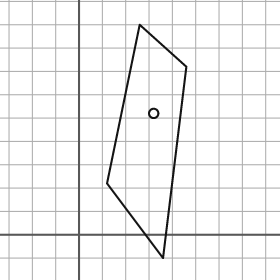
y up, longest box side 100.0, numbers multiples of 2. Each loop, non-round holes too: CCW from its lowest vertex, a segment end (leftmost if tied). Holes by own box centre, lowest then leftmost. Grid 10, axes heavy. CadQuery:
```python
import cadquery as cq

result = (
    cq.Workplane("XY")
    .moveTo(36.0, -10.0)
    .lineTo(46.0, 72.0)
    .lineTo(26.0, 90.0)
    .lineTo(12.0, 22.0)
    .close()
    .moveTo(32.0, 52.0)
    .circle(2.0)
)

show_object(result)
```